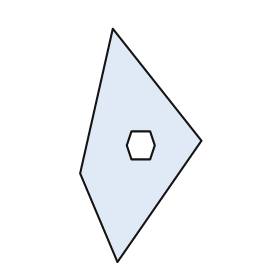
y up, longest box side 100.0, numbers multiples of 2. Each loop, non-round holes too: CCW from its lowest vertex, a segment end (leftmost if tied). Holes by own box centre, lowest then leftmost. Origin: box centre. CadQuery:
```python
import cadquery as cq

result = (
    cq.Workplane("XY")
    .moveTo(-10.0, -50.0)
    .lineTo(26.0, 2.0)
    .lineTo(-12.0, 50.0)
    .lineTo(-26.0, -12.0)
    .close()
    .moveTo(-4.0, -6.0)
    .lineTo(4.0, -6.0)
    .lineTo(6.0, 0.0)
    .lineTo(4.0, 6.0)
    .lineTo(-4.0, 6.0)
    .lineTo(-6.0, 0.0)
    .close()
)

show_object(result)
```